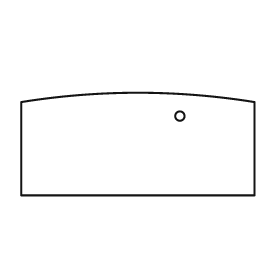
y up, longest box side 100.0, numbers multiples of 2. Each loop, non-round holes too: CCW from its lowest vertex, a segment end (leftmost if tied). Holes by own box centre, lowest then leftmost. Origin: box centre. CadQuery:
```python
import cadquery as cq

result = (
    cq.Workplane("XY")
    .moveTo(-50.0, -22.0)
    .lineTo(50.0, -22.0)
    .lineTo(50.0, 18.0)
    .threePointArc((0.0, 22.0), (-50.0, 18.0))
    .close()
    .moveTo(18.0, 12.0)
    .circle(2.0)
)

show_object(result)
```